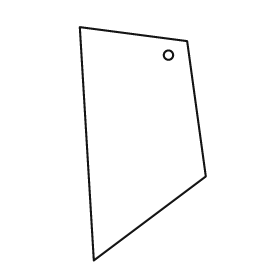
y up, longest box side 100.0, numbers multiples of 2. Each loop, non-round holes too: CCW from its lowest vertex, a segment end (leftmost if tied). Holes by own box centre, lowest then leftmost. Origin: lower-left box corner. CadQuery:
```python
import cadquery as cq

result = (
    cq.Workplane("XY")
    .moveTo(6.0, 0.0)
    .lineTo(54.0, 36.0)
    .lineTo(46.0, 94.0)
    .lineTo(0.0, 100.0)
    .close()
    .moveTo(38.0, 88.0)
    .circle(2.0)
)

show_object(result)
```